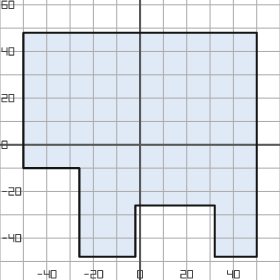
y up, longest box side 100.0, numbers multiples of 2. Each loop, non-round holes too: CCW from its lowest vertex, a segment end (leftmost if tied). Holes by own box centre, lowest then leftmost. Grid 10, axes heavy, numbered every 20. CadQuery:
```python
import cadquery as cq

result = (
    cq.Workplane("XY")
    .moveTo(-26.0, -48.0)
    .lineTo(-2.0, -48.0)
    .lineTo(-2.0, -26.0)
    .lineTo(32.0, -26.0)
    .lineTo(32.0, -48.0)
    .lineTo(50.0, -48.0)
    .lineTo(50.0, 48.0)
    .lineTo(-50.0, 48.0)
    .lineTo(-50.0, -10.0)
    .lineTo(-26.0, -10.0)
    .close()
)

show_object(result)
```